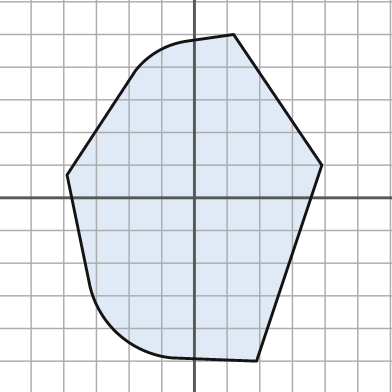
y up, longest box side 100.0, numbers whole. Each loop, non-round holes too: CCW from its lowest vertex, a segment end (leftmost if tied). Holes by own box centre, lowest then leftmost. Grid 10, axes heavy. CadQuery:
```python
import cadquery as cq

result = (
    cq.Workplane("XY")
    .moveTo(19.0, -50.0)
    .lineTo(39.0, 10.0)
    .lineTo(12.0, 50.0)
    .lineTo(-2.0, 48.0)
    .threePointArc((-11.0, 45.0), (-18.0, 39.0))
    .lineTo(-39.0, 7.0)
    .lineTo(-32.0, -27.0)
    .threePointArc((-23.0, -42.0), (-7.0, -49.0))
    .close()
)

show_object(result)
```